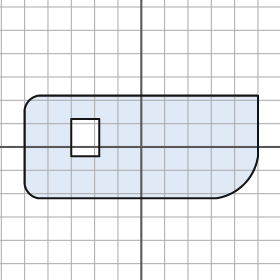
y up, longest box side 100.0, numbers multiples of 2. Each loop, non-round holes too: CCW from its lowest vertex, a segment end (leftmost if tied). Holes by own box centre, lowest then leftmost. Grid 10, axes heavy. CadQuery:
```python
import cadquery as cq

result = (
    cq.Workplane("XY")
    .moveTo(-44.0, -22.0)
    .lineTo(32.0, -22.0)
    .threePointArc((44.0, -16.0), (50.0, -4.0))
    .lineTo(50.0, 22.0)
    .lineTo(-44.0, 22.0)
    .threePointArc((-48.0, 20.0), (-50.0, 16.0))
    .lineTo(-50.0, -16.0)
    .threePointArc((-48.0, -20.0), (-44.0, -22.0))
    .close()
    .moveTo(-30.0, -4.0)
    .lineTo(-18.0, -4.0)
    .lineTo(-18.0, 12.0)
    .lineTo(-30.0, 12.0)
    .close()
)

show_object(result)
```